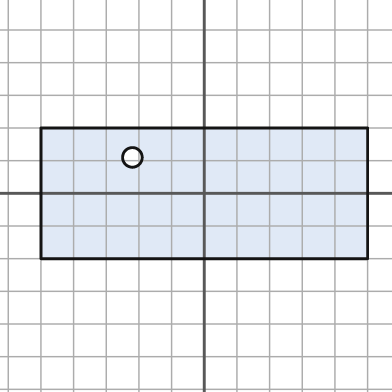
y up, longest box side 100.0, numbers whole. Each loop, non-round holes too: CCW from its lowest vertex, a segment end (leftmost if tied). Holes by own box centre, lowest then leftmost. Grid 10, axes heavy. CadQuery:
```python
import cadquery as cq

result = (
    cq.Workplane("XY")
    .moveTo(-50.0, -20.0)
    .lineTo(50.0, -20.0)
    .lineTo(50.0, 20.0)
    .lineTo(-50.0, 20.0)
    .close()
    .moveTo(-22.0, 11.0)
    .circle(3.0)
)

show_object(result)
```